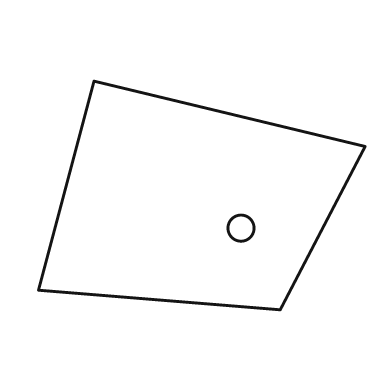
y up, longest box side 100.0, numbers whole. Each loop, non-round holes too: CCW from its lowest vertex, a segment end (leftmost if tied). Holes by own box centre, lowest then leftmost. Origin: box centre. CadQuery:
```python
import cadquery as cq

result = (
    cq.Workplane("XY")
    .moveTo(24.0, -35.0)
    .lineTo(50.0, 15.0)
    .lineTo(-33.0, 35.0)
    .lineTo(-50.0, -29.0)
    .close()
    .moveTo(12.0, -10.0)
    .circle(4.0)
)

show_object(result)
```